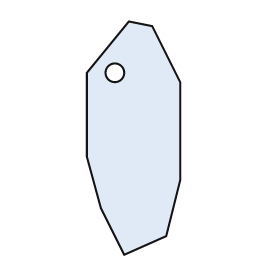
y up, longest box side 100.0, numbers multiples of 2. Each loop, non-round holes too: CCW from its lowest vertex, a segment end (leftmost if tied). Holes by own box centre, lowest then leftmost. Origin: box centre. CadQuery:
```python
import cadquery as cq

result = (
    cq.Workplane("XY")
    .moveTo(-4.0, -50.0)
    .lineTo(14.0, -42.0)
    .lineTo(20.0, -18.0)
    .lineTo(20.0, 24.0)
    .lineTo(8.0, 48.0)
    .lineTo(-2.0, 50.0)
    .lineTo(-20.0, 28.0)
    .lineTo(-20.0, -8.0)
    .lineTo(-14.0, -30.0)
    .close()
    .moveTo(-8.0, 28.0)
    .circle(4.0)
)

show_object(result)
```